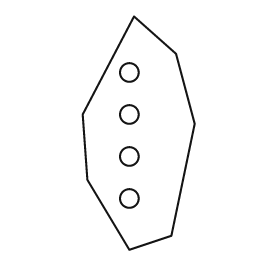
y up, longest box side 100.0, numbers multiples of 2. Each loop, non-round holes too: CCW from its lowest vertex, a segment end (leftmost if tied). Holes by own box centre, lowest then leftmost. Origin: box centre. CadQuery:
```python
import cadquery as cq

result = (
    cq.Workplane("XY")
    .moveTo(-4.0, -50.0)
    .lineTo(14.0, -44.0)
    .lineTo(24.0, 4.0)
    .lineTo(16.0, 34.0)
    .lineTo(-2.0, 50.0)
    .lineTo(-24.0, 8.0)
    .lineTo(-22.0, -20.0)
    .close()
    .moveTo(-4.0, -28.0)
    .circle(4.0)
    .moveTo(-4.0, -10.0)
    .circle(4.0)
    .moveTo(-4.0, 8.0)
    .circle(4.0)
    .moveTo(-4.0, 26.0)
    .circle(4.0)
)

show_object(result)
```